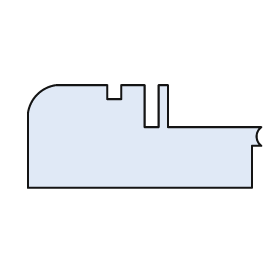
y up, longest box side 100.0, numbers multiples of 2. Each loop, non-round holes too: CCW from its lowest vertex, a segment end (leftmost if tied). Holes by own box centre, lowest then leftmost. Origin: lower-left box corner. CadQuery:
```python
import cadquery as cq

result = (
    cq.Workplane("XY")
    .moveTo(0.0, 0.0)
    .lineTo(96.0, 0.0)
    .lineTo(96.0, 18.0)
    .lineTo(100.0, 18.0)
    .threePointArc((98.0, 22.0), (100.0, 26.0))
    .lineTo(60.0, 26.0)
    .lineTo(60.0, 44.0)
    .lineTo(56.0, 44.0)
    .lineTo(56.0, 26.0)
    .lineTo(50.0, 26.0)
    .lineTo(50.0, 44.0)
    .lineTo(40.0, 44.0)
    .lineTo(40.0, 38.0)
    .lineTo(34.0, 38.0)
    .lineTo(34.0, 44.0)
    .lineTo(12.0, 44.0)
    .threePointArc((4.0, 40.0), (0.0, 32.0))
    .close()
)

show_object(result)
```